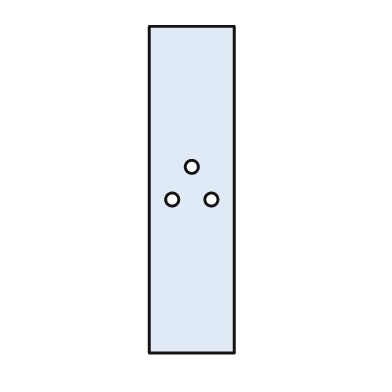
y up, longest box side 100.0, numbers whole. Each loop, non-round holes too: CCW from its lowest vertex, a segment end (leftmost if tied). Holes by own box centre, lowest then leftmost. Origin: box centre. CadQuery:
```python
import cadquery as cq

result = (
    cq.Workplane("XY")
    .moveTo(-13.0, -50.0)
    .lineTo(13.0, -50.0)
    .lineTo(13.0, 50.0)
    .lineTo(-13.0, 50.0)
    .close()
    .moveTo(-6.0, -3.0)
    .circle(2.0)
    .moveTo(6.0, -3.0)
    .circle(2.0)
    .moveTo(0.0, 7.0)
    .circle(2.0)
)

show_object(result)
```